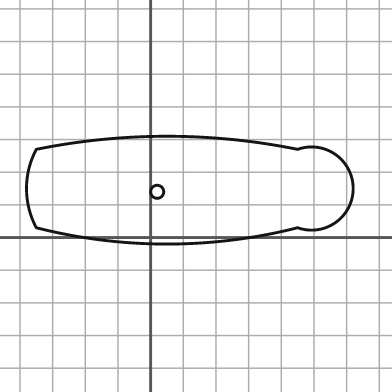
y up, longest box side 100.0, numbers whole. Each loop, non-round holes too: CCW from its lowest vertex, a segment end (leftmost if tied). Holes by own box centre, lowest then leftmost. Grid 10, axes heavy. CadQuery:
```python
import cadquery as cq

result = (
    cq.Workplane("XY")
    .moveTo(-35.0, 3.0)
    .threePointArc((5.0, -2.0), (45.0, 3.0))
    .threePointArc((62.0, 15.0), (45.0, 27.0))
    .threePointArc((5.0, 31.0), (-35.0, 27.0))
    .threePointArc((-38.0, 15.0), (-35.0, 3.0))
    .close()
    .moveTo(2.0, 14.0)
    .circle(2.0)
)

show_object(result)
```